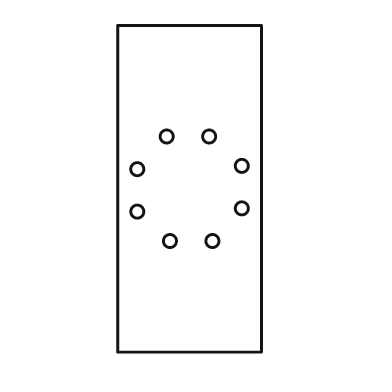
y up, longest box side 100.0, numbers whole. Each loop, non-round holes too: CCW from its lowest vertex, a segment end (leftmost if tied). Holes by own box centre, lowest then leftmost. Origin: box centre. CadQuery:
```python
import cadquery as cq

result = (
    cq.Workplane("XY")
    .moveTo(-22.0, -50.0)
    .lineTo(22.0, -50.0)
    .lineTo(22.0, 50.0)
    .lineTo(-22.0, 50.0)
    .close()
    .moveTo(-6.0, -16.0)
    .circle(2.0)
    .moveTo(7.0, -16.0)
    .circle(2.0)
    .moveTo(-16.0, -7.0)
    .circle(2.0)
    .moveTo(16.0, -6.0)
    .circle(2.0)
    .moveTo(-16.0, 6.0)
    .circle(2.0)
    .moveTo(16.0, 7.0)
    .circle(2.0)
    .moveTo(-7.0, 16.0)
    .circle(2.0)
    .moveTo(6.0, 16.0)
    .circle(2.0)
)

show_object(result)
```